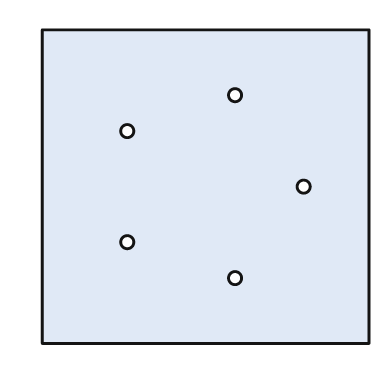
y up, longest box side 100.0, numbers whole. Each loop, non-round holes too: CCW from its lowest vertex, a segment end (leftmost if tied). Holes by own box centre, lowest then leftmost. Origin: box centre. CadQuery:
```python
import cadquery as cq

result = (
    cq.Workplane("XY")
    .moveTo(-50.0, -48.0)
    .lineTo(50.0, -48.0)
    .lineTo(50.0, 48.0)
    .lineTo(-50.0, 48.0)
    .close()
    .moveTo(9.0, -28.0)
    .circle(2.0)
    .moveTo(-24.0, -17.0)
    .circle(2.0)
    .moveTo(30.0, 0.0)
    .circle(2.0)
    .moveTo(-24.0, 17.0)
    .circle(2.0)
    .moveTo(9.0, 28.0)
    .circle(2.0)
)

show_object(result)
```